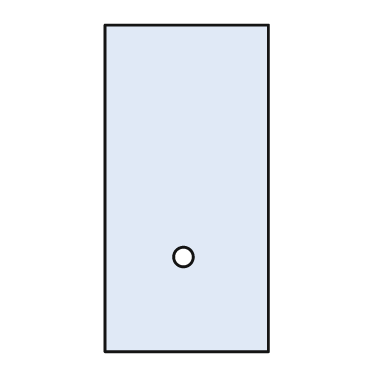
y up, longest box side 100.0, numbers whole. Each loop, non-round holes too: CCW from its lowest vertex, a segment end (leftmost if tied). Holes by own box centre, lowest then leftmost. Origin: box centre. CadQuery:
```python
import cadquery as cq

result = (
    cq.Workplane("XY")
    .moveTo(-25.0, -50.0)
    .lineTo(25.0, -50.0)
    .lineTo(25.0, 50.0)
    .lineTo(-25.0, 50.0)
    .close()
    .moveTo(-1.0, -21.0)
    .circle(3.0)
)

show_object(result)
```